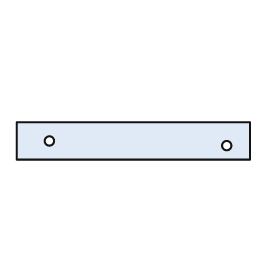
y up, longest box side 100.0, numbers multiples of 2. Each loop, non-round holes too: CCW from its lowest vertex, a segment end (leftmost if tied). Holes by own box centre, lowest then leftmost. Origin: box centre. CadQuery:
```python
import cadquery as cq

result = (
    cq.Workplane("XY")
    .moveTo(-50.0, -8.0)
    .lineTo(50.0, -8.0)
    .lineTo(50.0, 8.0)
    .lineTo(-50.0, 8.0)
    .close()
    .moveTo(40.0, -2.0)
    .circle(2.0)
    .moveTo(-36.0, 0.0)
    .circle(2.0)
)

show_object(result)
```